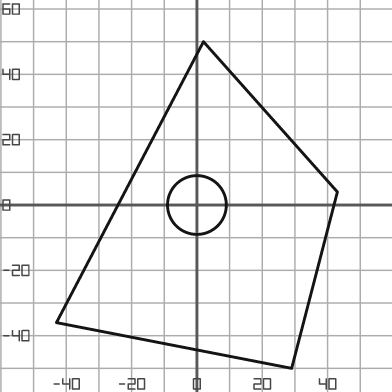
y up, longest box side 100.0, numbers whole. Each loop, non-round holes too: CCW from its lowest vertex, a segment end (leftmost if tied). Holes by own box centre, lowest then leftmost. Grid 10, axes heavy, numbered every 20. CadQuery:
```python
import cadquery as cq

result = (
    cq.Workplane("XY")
    .moveTo(29.0, -50.0)
    .lineTo(43.0, 4.0)
    .lineTo(2.0, 50.0)
    .lineTo(-43.0, -36.0)
    .close()
    .moveTo(0.0, 0.0)
    .circle(9.0)
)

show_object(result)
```